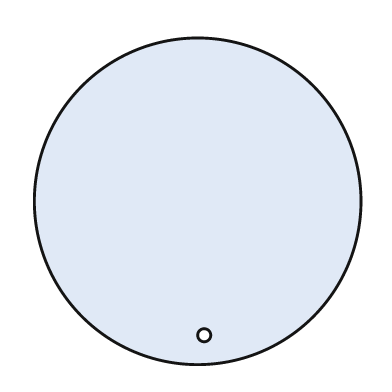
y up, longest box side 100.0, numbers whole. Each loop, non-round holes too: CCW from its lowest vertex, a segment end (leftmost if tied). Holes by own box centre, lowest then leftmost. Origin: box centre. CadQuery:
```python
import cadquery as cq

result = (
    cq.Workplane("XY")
    .moveTo(0.0, 0.0)
    .circle(50.0)
    .moveTo(2.0, -41.0)
    .circle(2.0)
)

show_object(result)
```